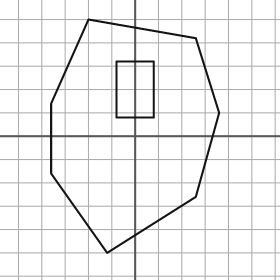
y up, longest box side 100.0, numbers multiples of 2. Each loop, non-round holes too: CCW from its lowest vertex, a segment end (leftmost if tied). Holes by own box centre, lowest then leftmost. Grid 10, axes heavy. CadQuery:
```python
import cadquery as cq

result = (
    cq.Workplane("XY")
    .moveTo(-12.0, -50.0)
    .lineTo(26.0, -26.0)
    .lineTo(36.0, 10.0)
    .lineTo(26.0, 42.0)
    .lineTo(-20.0, 50.0)
    .lineTo(-36.0, 14.0)
    .lineTo(-36.0, -16.0)
    .close()
    .moveTo(-8.0, 8.0)
    .lineTo(8.0, 8.0)
    .lineTo(8.0, 32.0)
    .lineTo(-8.0, 32.0)
    .close()
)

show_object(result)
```